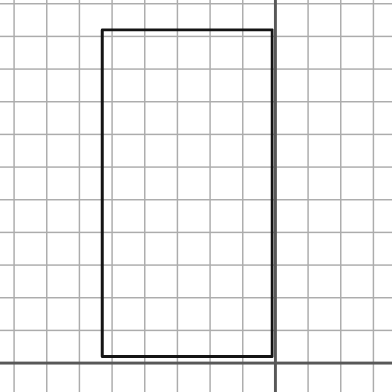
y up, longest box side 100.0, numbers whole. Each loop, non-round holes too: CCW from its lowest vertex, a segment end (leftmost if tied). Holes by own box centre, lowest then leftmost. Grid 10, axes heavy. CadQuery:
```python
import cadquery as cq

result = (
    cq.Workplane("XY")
    .moveTo(-53.0, 2.0)
    .lineTo(-1.0, 2.0)
    .lineTo(-1.0, 102.0)
    .lineTo(-53.0, 102.0)
    .close()
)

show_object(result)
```